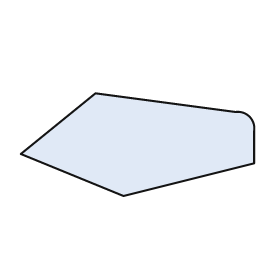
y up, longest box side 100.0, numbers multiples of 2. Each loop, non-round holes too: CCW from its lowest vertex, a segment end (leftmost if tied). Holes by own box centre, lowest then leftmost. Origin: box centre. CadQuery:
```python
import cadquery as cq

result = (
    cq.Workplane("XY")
    .moveTo(-6.0, -22.0)
    .lineTo(50.0, -8.0)
    .lineTo(50.0, 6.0)
    .threePointArc((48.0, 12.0), (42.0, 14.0))
    .lineTo(-18.0, 22.0)
    .lineTo(-50.0, -4.0)
    .close()
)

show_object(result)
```